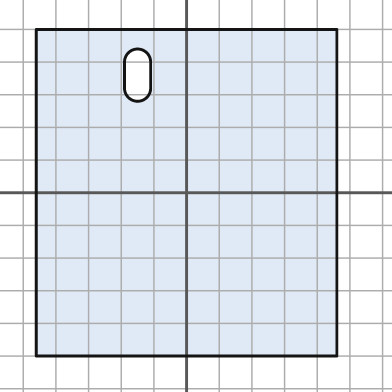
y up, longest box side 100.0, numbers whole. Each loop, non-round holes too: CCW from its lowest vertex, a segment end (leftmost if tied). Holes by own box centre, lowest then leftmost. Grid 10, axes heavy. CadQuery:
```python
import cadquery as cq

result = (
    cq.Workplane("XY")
    .moveTo(-46.0, -50.0)
    .lineTo(46.0, -50.0)
    .lineTo(46.0, 50.0)
    .lineTo(-46.0, 50.0)
    .close()
    .moveTo(-19.0, 32.0)
    .threePointArc((-15.0, 28.0), (-11.0, 32.0))
    .lineTo(-11.0, 40.0)
    .threePointArc((-15.0, 44.0), (-19.0, 40.0))
    .close()
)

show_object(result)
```